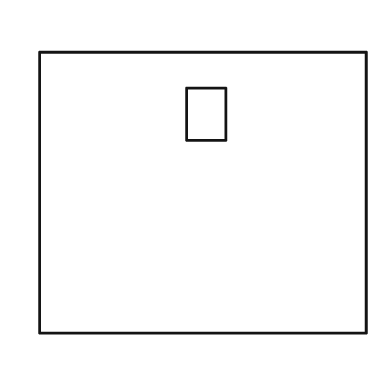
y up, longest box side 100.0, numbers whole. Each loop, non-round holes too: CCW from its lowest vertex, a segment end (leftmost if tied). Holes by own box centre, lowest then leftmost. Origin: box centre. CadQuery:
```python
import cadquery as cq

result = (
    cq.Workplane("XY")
    .moveTo(-50.0, -43.0)
    .lineTo(50.0, -43.0)
    .lineTo(50.0, 43.0)
    .lineTo(-50.0, 43.0)
    .close()
    .moveTo(-5.0, 16.0)
    .lineTo(7.0, 16.0)
    .lineTo(7.0, 32.0)
    .lineTo(-5.0, 32.0)
    .close()
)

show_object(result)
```